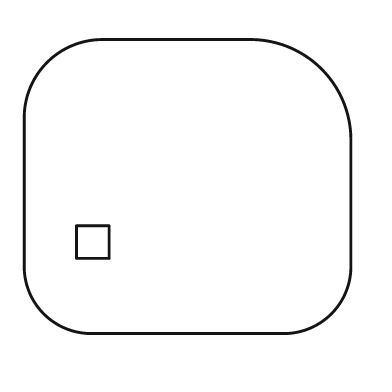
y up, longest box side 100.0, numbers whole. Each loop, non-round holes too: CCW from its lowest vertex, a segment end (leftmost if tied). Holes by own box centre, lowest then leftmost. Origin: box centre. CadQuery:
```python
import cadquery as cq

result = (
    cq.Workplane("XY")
    .moveTo(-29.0, -45.0)
    .lineTo(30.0, -45.0)
    .threePointArc((44.0, -39.0), (50.0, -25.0))
    .lineTo(50.0, 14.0)
    .threePointArc((41.0, 36.0), (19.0, 45.0))
    .lineTo(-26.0, 45.0)
    .threePointArc((-43.0, 38.0), (-50.0, 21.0))
    .lineTo(-50.0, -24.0)
    .threePointArc((-44.0, -39.0), (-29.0, -45.0))
    .close()
    .moveTo(-34.0, -22.0)
    .lineTo(-24.0, -22.0)
    .lineTo(-24.0, -12.0)
    .lineTo(-34.0, -12.0)
    .close()
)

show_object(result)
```